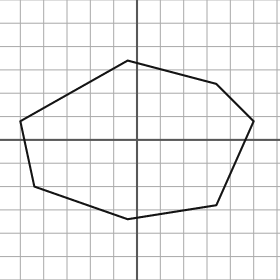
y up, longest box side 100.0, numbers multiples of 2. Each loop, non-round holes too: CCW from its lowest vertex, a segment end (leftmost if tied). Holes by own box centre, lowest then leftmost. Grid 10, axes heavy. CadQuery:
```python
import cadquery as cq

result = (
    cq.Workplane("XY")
    .moveTo(-4.0, -34.0)
    .lineTo(34.0, -28.0)
    .lineTo(50.0, 8.0)
    .lineTo(34.0, 24.0)
    .lineTo(-4.0, 34.0)
    .lineTo(-50.0, 8.0)
    .lineTo(-44.0, -20.0)
    .close()
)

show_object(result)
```